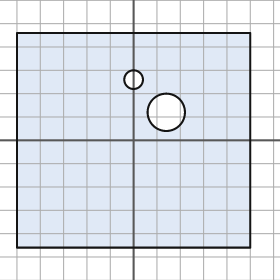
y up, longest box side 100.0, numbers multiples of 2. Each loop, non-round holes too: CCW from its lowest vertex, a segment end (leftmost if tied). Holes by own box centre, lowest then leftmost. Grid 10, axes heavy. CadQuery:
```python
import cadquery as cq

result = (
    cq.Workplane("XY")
    .moveTo(-50.0, -46.0)
    .lineTo(50.0, -46.0)
    .lineTo(50.0, 46.0)
    .lineTo(-50.0, 46.0)
    .close()
    .moveTo(14.0, 12.0)
    .circle(8.0)
    .moveTo(0.0, 26.0)
    .circle(4.0)
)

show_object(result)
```